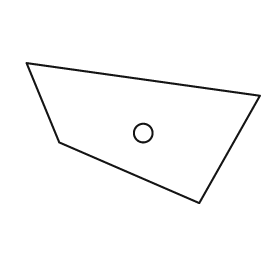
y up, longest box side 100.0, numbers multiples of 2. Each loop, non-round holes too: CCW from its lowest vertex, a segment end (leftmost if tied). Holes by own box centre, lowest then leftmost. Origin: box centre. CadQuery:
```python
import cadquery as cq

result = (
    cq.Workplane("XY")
    .moveTo(24.0, -30.0)
    .lineTo(50.0, 16.0)
    .lineTo(-50.0, 30.0)
    .lineTo(-36.0, -4.0)
    .close()
    .moveTo(0.0, 0.0)
    .circle(4.0)
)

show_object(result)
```